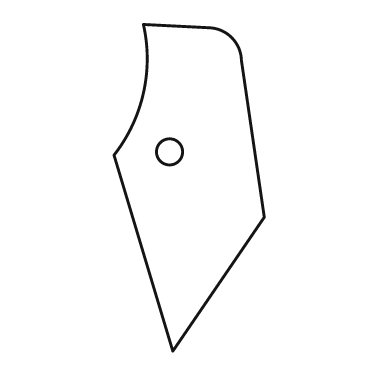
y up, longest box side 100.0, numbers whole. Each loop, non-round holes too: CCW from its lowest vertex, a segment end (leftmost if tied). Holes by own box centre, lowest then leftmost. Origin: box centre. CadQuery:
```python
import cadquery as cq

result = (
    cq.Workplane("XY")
    .moveTo(-5.0, -50.0)
    .lineTo(23.0, -9.0)
    .lineTo(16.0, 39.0)
    .threePointArc((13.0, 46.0), (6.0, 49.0))
    .lineTo(-14.0, 50.0)
    .threePointArc((-14.0, 29.0), (-23.0, 10.0))
    .close()
    .moveTo(-6.0, 11.0)
    .circle(4.0)
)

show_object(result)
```